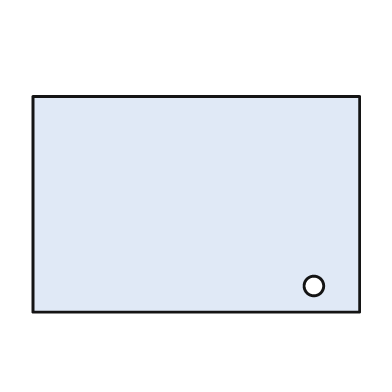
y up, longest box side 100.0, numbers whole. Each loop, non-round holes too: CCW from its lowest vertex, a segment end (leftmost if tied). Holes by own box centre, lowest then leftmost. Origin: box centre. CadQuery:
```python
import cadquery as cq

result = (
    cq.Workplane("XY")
    .moveTo(-50.0, -33.0)
    .lineTo(50.0, -33.0)
    .lineTo(50.0, 33.0)
    .lineTo(-50.0, 33.0)
    .close()
    .moveTo(36.0, -25.0)
    .circle(3.0)
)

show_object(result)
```